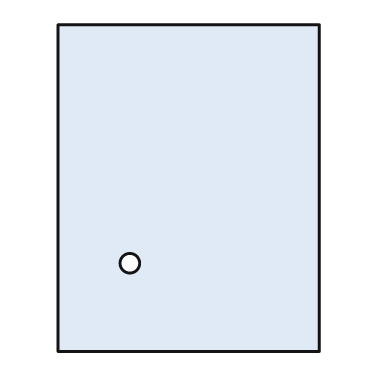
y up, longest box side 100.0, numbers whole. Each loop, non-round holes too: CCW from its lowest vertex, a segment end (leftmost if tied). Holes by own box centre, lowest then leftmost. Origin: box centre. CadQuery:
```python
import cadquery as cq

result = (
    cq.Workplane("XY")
    .moveTo(-40.0, -50.0)
    .lineTo(40.0, -50.0)
    .lineTo(40.0, 50.0)
    .lineTo(-40.0, 50.0)
    .close()
    .moveTo(-18.0, -23.0)
    .circle(3.0)
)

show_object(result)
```